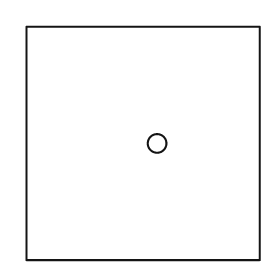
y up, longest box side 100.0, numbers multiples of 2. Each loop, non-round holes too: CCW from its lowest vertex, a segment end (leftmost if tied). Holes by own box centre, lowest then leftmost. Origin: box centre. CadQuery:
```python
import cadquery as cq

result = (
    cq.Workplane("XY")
    .moveTo(-50.0, -50.0)
    .lineTo(50.0, -50.0)
    .lineTo(50.0, 50.0)
    .lineTo(-50.0, 50.0)
    .close()
    .moveTo(6.0, 0.0)
    .circle(4.0)
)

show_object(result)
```